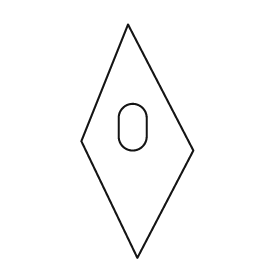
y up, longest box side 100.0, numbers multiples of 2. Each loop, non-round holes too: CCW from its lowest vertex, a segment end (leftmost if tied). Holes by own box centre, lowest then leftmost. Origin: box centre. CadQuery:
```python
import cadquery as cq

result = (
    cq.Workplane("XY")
    .moveTo(0.0, -50.0)
    .lineTo(24.0, -4.0)
    .lineTo(-4.0, 50.0)
    .lineTo(-24.0, 0.0)
    .close()
    .moveTo(-8.0, 2.0)
    .threePointArc((-2.0, -4.0), (4.0, 2.0))
    .lineTo(4.0, 10.0)
    .threePointArc((-2.0, 16.0), (-8.0, 10.0))
    .close()
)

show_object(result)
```